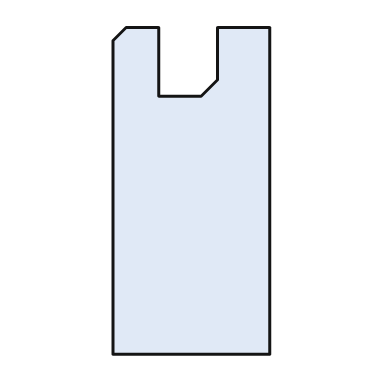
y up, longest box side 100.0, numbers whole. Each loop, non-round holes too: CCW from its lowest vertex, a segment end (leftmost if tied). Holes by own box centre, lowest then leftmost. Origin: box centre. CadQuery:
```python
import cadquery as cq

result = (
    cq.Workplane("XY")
    .moveTo(-24.0, -50.0)
    .lineTo(24.0, -50.0)
    .lineTo(24.0, 50.0)
    .lineTo(8.0, 50.0)
    .lineTo(8.0, 34.0)
    .lineTo(3.0, 29.0)
    .lineTo(-10.0, 29.0)
    .lineTo(-10.0, 50.0)
    .lineTo(-20.0, 50.0)
    .lineTo(-24.0, 46.0)
    .close()
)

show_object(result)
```